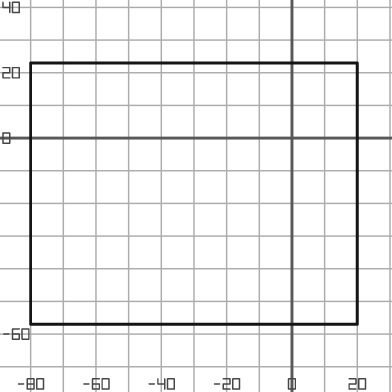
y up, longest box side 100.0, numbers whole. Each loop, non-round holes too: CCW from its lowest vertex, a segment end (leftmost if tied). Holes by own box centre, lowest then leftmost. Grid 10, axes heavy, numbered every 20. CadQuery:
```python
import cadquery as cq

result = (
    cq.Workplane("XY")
    .moveTo(-80.0, -57.0)
    .lineTo(20.0, -57.0)
    .lineTo(20.0, 23.0)
    .lineTo(-80.0, 23.0)
    .close()
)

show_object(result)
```